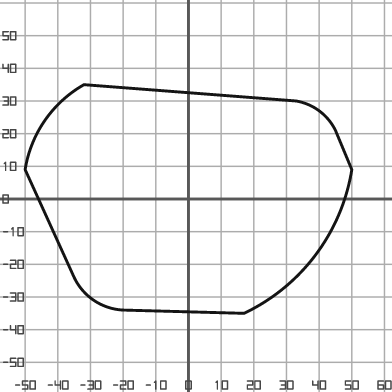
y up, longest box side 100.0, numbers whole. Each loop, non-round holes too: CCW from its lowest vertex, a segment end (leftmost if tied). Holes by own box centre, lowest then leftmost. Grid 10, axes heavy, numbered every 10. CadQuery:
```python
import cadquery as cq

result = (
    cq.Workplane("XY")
    .moveTo(17.0, -35.0)
    .threePointArc((39.0, -17.0), (50.0, 9.0))
    .lineTo(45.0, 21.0)
    .threePointArc((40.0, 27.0), (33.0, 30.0))
    .lineTo(-32.0, 35.0)
    .threePointArc((-44.0, 24.0), (-50.0, 9.0))
    .lineTo(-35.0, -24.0)
    .threePointArc((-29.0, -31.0), (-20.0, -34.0))
    .close()
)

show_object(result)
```